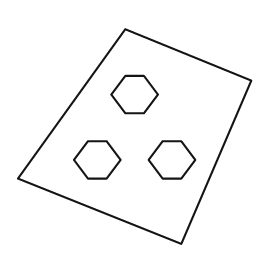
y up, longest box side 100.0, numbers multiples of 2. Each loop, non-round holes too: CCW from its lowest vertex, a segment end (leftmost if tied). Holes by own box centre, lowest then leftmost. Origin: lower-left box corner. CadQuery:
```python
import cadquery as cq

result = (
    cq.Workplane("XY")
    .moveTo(70.0, 0.0)
    .lineTo(100.0, 70.0)
    .lineTo(46.0, 92.0)
    .lineTo(0.0, 28.0)
    .close()
    .moveTo(30.0, 28.0)
    .lineTo(38.0, 28.0)
    .lineTo(44.0, 36.0)
    .lineTo(38.0, 44.0)
    .lineTo(30.0, 44.0)
    .lineTo(24.0, 36.0)
    .close()
    .moveTo(62.0, 28.0)
    .lineTo(70.0, 28.0)
    .lineTo(76.0, 36.0)
    .lineTo(70.0, 44.0)
    .lineTo(62.0, 44.0)
    .lineTo(56.0, 36.0)
    .close()
    .moveTo(46.0, 56.0)
    .lineTo(54.0, 56.0)
    .lineTo(60.0, 64.0)
    .lineTo(54.0, 72.0)
    .lineTo(46.0, 72.0)
    .lineTo(40.0, 64.0)
    .close()
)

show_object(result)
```